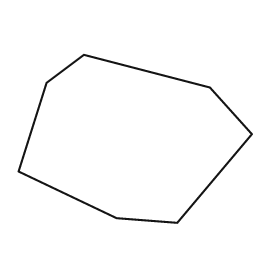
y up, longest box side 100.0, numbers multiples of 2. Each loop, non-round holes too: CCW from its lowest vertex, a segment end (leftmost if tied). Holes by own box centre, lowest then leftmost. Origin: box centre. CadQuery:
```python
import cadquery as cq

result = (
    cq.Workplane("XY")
    .moveTo(18.0, -36.0)
    .lineTo(50.0, 2.0)
    .lineTo(32.0, 22.0)
    .lineTo(-22.0, 36.0)
    .lineTo(-38.0, 24.0)
    .lineTo(-50.0, -14.0)
    .lineTo(-8.0, -34.0)
    .close()
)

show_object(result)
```